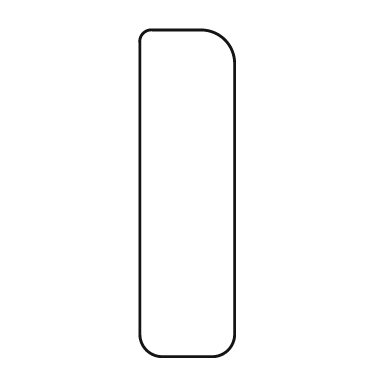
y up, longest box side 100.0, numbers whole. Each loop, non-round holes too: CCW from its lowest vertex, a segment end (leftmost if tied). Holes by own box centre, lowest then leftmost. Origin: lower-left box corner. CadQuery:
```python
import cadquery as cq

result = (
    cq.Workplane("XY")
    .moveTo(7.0, 0.0)
    .lineTo(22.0, 0.0)
    .threePointArc((27.0, 2.0), (29.0, 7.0))
    .lineTo(29.0, 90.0)
    .threePointArc((26.0, 97.0), (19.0, 100.0))
    .lineTo(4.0, 100.0)
    .threePointArc((1.0, 99.0), (0.0, 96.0))
    .lineTo(0.0, 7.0)
    .threePointArc((2.0, 2.0), (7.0, 0.0))
    .close()
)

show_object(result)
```